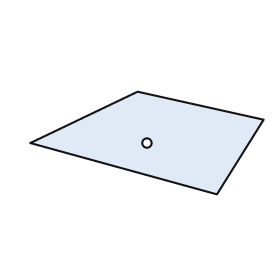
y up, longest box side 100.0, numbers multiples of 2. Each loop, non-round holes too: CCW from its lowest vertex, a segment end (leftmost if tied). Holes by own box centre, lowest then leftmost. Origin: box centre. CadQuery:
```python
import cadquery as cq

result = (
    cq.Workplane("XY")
    .moveTo(30.0, -22.0)
    .lineTo(50.0, 10.0)
    .lineTo(-4.0, 22.0)
    .lineTo(-50.0, 0.0)
    .close()
    .moveTo(0.0, 0.0)
    .circle(2.0)
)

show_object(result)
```